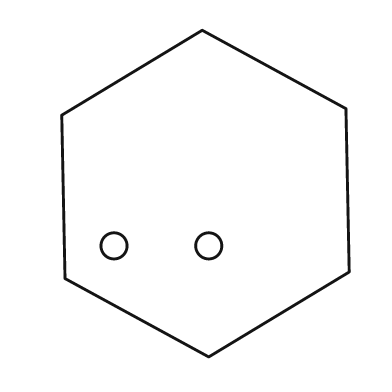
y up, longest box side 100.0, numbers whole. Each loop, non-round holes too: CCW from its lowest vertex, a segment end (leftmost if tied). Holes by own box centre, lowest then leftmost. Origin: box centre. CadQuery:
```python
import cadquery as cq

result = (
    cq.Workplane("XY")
    .moveTo(1.0, -50.0)
    .lineTo(44.0, -24.0)
    .lineTo(43.0, 26.0)
    .lineTo(-1.0, 50.0)
    .lineTo(-44.0, 24.0)
    .lineTo(-43.0, -26.0)
    .close()
    .moveTo(-28.0, -16.0)
    .circle(4.0)
    .moveTo(1.0, -16.0)
    .circle(4.0)
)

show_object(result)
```